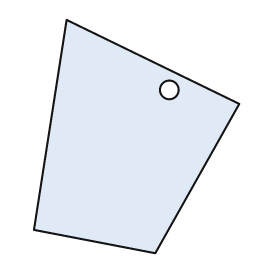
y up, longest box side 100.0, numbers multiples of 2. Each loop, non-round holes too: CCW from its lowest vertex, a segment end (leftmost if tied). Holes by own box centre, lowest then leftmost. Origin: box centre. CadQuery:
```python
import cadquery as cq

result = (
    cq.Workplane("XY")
    .moveTo(8.0, -50.0)
    .lineTo(44.0, 14.0)
    .lineTo(-30.0, 50.0)
    .lineTo(-44.0, -40.0)
    .close()
    .moveTo(14.0, 20.0)
    .circle(4.0)
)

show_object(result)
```